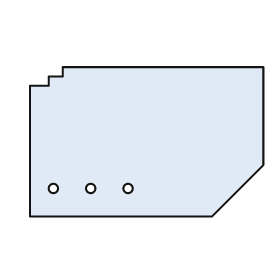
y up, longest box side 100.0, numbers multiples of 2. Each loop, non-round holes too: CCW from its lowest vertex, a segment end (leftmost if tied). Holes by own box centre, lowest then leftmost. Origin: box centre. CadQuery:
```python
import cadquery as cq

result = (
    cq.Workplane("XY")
    .moveTo(-50.0, -32.0)
    .lineTo(28.0, -32.0)
    .lineTo(50.0, -10.0)
    .lineTo(50.0, 32.0)
    .lineTo(-36.0, 32.0)
    .lineTo(-36.0, 28.0)
    .lineTo(-42.0, 28.0)
    .lineTo(-42.0, 24.0)
    .lineTo(-50.0, 24.0)
    .close()
    .moveTo(-40.0, -20.0)
    .circle(2.0)
    .moveTo(-24.0, -20.0)
    .circle(2.0)
    .moveTo(-8.0, -20.0)
    .circle(2.0)
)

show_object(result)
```